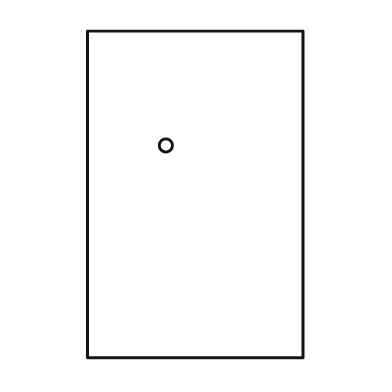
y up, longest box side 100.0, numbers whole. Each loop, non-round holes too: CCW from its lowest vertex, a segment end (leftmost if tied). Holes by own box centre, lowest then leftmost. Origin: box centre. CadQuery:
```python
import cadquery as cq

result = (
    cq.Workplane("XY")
    .moveTo(-33.0, -50.0)
    .lineTo(33.0, -50.0)
    .lineTo(33.0, 50.0)
    .lineTo(-33.0, 50.0)
    .close()
    .moveTo(-9.0, 15.0)
    .circle(2.0)
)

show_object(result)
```